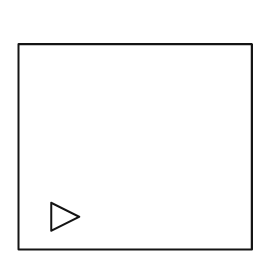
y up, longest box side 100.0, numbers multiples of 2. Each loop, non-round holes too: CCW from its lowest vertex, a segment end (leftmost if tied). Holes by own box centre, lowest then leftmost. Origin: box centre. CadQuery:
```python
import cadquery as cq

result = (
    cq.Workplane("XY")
    .moveTo(-50.0, -44.0)
    .lineTo(50.0, -44.0)
    .lineTo(50.0, 44.0)
    .lineTo(-50.0, 44.0)
    .close()
    .moveTo(-36.0, -36.0)
    .lineTo(-24.0, -30.0)
    .lineTo(-36.0, -24.0)
    .close()
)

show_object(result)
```